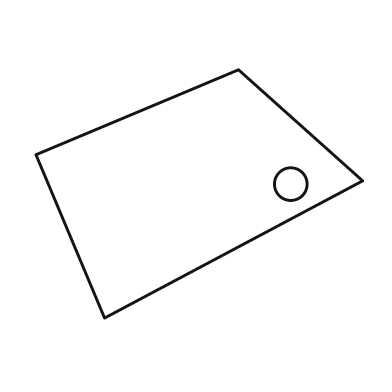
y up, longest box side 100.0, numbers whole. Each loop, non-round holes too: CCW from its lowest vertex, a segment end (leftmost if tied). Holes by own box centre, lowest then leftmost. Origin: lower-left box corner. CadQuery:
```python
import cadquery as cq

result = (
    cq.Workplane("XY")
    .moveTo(21.0, 0.0)
    .lineTo(100.0, 42.0)
    .lineTo(62.0, 76.0)
    .lineTo(0.0, 50.0)
    .close()
    .moveTo(78.0, 41.0)
    .circle(5.0)
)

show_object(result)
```